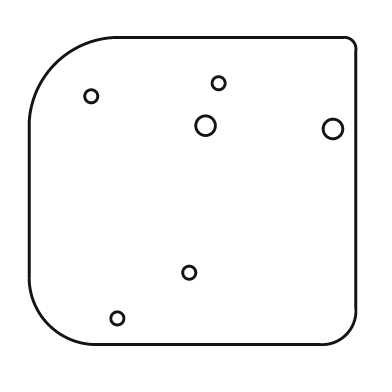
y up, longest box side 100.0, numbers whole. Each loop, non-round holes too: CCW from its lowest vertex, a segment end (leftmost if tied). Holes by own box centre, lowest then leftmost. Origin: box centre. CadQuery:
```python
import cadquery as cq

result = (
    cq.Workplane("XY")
    .moveTo(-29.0, -47.0)
    .lineTo(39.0, -47.0)
    .threePointArc((47.0, -44.0), (50.0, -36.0))
    .lineTo(50.0, 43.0)
    .threePointArc((49.0, 46.0), (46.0, 47.0))
    .lineTo(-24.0, 47.0)
    .threePointArc((-42.0, 39.0), (-50.0, 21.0))
    .lineTo(-50.0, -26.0)
    .threePointArc((-44.0, -41.0), (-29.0, -47.0))
    .close()
    .moveTo(-23.0, -39.0)
    .circle(2.0)
    .moveTo(-1.0, -25.0)
    .circle(2.0)
    .moveTo(43.0, 19.0)
    .circle(3.0)
    .moveTo(4.0, 20.0)
    .circle(3.0)
    .moveTo(-31.0, 29.0)
    .circle(2.0)
    .moveTo(8.0, 33.0)
    .circle(2.0)
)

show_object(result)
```